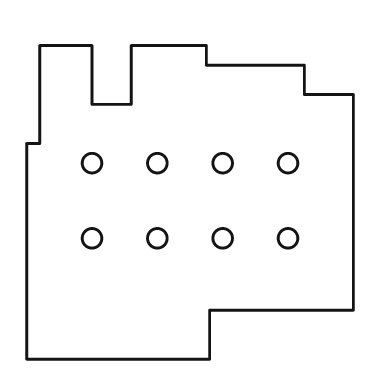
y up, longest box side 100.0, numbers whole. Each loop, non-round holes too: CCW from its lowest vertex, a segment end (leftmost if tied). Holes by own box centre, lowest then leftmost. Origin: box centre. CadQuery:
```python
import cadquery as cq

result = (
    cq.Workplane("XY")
    .moveTo(-50.0, -48.0)
    .lineTo(6.0, -48.0)
    .lineTo(6.0, -33.0)
    .lineTo(50.0, -33.0)
    .lineTo(50.0, 33.0)
    .lineTo(35.0, 33.0)
    .lineTo(35.0, 42.0)
    .lineTo(5.0, 42.0)
    .lineTo(5.0, 48.0)
    .lineTo(-18.0, 48.0)
    .lineTo(-18.0, 30.0)
    .lineTo(-30.0, 30.0)
    .lineTo(-30.0, 48.0)
    .lineTo(-46.0, 48.0)
    .lineTo(-46.0, 18.0)
    .lineTo(-50.0, 18.0)
    .close()
    .moveTo(-30.0, -11.0)
    .circle(3.0)
    .moveTo(-10.0, -11.0)
    .circle(3.0)
    .moveTo(10.0, -11.0)
    .circle(3.0)
    .moveTo(30.0, -11.0)
    .circle(3.0)
    .moveTo(-30.0, 12.0)
    .circle(3.0)
    .moveTo(-10.0, 12.0)
    .circle(3.0)
    .moveTo(10.0, 12.0)
    .circle(3.0)
    .moveTo(30.0, 12.0)
    .circle(3.0)
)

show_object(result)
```